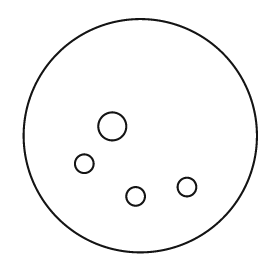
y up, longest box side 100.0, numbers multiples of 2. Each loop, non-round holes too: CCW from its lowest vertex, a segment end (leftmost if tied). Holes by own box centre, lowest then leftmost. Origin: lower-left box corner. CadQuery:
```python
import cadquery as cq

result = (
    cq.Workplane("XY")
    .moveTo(50.0, 50.0)
    .circle(50.0)
    .moveTo(48.0, 24.0)
    .circle(4.0)
    .moveTo(70.0, 28.0)
    .circle(4.0)
    .moveTo(26.0, 38.0)
    .circle(4.0)
    .moveTo(38.0, 54.0)
    .circle(6.0)
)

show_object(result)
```